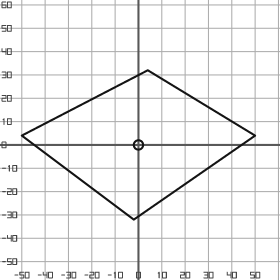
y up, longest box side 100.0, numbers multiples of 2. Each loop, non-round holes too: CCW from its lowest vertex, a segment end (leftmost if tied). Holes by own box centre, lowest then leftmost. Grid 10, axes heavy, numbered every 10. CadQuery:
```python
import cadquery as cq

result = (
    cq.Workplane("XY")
    .moveTo(-2.0, -32.0)
    .lineTo(50.0, 4.0)
    .lineTo(4.0, 32.0)
    .lineTo(-50.0, 4.0)
    .close()
    .moveTo(0.0, 0.0)
    .circle(2.0)
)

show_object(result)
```